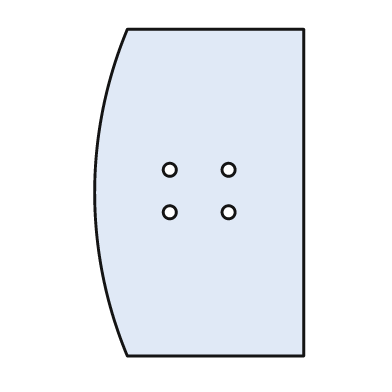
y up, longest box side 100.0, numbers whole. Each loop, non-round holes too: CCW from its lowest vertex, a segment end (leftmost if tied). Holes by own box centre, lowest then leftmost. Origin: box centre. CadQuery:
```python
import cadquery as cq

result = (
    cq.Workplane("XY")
    .moveTo(-22.0, -50.0)
    .lineTo(32.0, -50.0)
    .lineTo(32.0, 50.0)
    .lineTo(-22.0, 50.0)
    .threePointArc((-32.0, 0.0), (-22.0, -50.0))
    .close()
    .moveTo(-9.0, -6.0)
    .circle(2.0)
    .moveTo(9.0, -6.0)
    .circle(2.0)
    .moveTo(-9.0, 7.0)
    .circle(2.0)
    .moveTo(9.0, 7.0)
    .circle(2.0)
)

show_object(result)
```